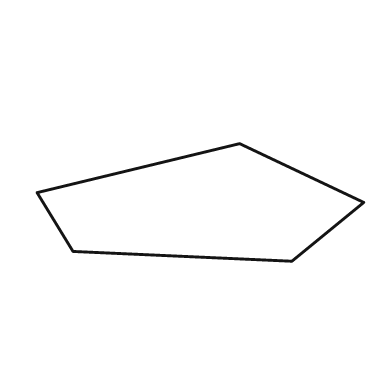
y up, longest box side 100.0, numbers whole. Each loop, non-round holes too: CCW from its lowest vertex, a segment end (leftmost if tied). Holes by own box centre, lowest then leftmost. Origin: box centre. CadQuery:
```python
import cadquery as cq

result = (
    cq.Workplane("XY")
    .moveTo(28.0, -18.0)
    .lineTo(50.0, 0.0)
    .lineTo(12.0, 18.0)
    .lineTo(-50.0, 3.0)
    .lineTo(-39.0, -15.0)
    .close()
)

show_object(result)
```